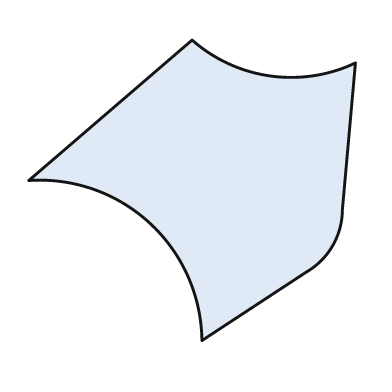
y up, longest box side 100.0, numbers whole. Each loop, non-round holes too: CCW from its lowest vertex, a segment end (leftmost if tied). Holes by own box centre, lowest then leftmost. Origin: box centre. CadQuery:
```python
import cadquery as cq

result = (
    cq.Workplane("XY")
    .moveTo(3.0, -46.0)
    .lineTo(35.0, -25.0)
    .threePointArc((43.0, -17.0), (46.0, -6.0))
    .lineTo(50.0, 39.0)
    .threePointArc((24.0, 35.0), (0.0, 46.0))
    .lineTo(-50.0, 3.0)
    .threePointArc((-13.0, -10.0), (3.0, -46.0))
    .close()
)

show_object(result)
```